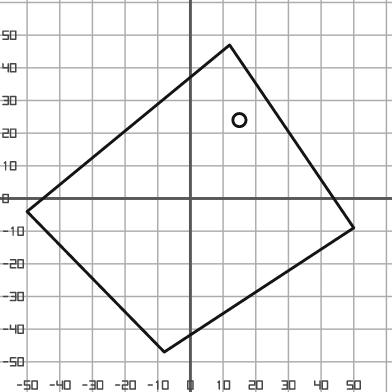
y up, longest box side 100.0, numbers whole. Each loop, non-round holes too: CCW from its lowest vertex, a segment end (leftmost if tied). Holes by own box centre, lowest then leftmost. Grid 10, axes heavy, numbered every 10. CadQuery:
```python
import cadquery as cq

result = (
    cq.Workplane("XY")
    .moveTo(-8.0, -47.0)
    .lineTo(50.0, -9.0)
    .lineTo(12.0, 47.0)
    .lineTo(-50.0, -4.0)
    .close()
    .moveTo(15.0, 24.0)
    .circle(2.0)
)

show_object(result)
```